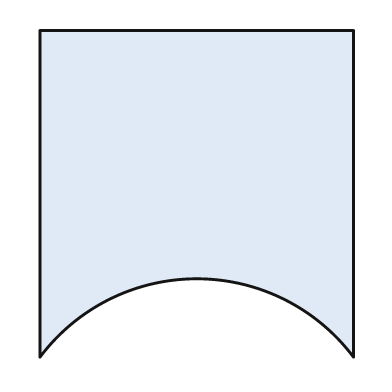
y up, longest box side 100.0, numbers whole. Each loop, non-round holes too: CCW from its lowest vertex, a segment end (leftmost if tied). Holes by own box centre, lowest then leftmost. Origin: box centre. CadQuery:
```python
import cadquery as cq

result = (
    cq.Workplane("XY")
    .moveTo(-48.0, -50.0)
    .threePointArc((0.0, -26.0), (48.0, -50.0))
    .lineTo(48.0, 50.0)
    .lineTo(-48.0, 50.0)
    .close()
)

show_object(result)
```